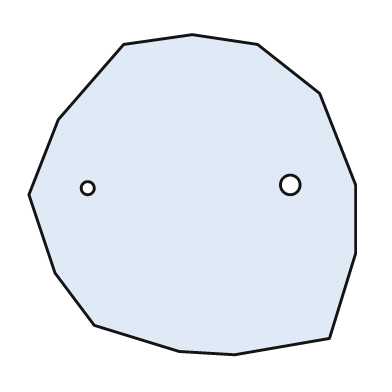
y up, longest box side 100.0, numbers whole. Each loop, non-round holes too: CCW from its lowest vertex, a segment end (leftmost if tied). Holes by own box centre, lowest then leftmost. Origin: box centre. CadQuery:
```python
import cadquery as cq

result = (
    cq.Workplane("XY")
    .moveTo(13.0, -49.0)
    .lineTo(42.0, -44.0)
    .lineTo(50.0, -18.0)
    .lineTo(50.0, 3.0)
    .lineTo(39.0, 31.0)
    .lineTo(20.0, 46.0)
    .lineTo(0.0, 49.0)
    .lineTo(-21.0, 46.0)
    .lineTo(-41.0, 23.0)
    .lineTo(-50.0, 0.0)
    .lineTo(-42.0, -24.0)
    .lineTo(-30.0, -40.0)
    .lineTo(-4.0, -48.0)
    .close()
    .moveTo(-32.0, 2.0)
    .circle(2.0)
    .moveTo(30.0, 3.0)
    .circle(3.0)
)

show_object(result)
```